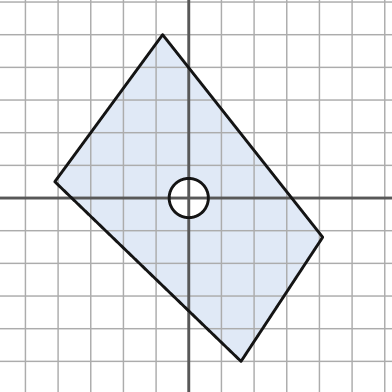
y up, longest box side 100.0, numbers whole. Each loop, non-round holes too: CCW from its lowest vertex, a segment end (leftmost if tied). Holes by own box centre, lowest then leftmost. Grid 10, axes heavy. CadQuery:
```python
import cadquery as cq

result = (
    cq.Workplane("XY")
    .moveTo(16.0, -50.0)
    .lineTo(41.0, -12.0)
    .lineTo(-8.0, 50.0)
    .lineTo(-41.0, 5.0)
    .close()
    .moveTo(0.0, 0.0)
    .circle(6.0)
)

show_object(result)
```